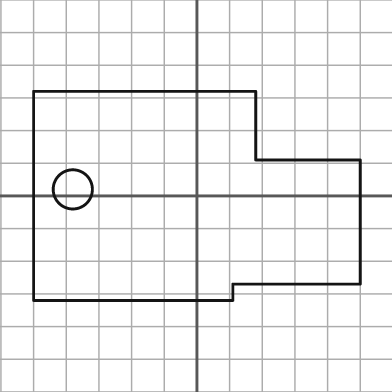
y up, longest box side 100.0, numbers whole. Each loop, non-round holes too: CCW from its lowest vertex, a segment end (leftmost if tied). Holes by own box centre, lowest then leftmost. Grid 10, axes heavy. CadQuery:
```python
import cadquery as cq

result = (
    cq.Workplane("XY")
    .moveTo(-50.0, -32.0)
    .lineTo(11.0, -32.0)
    .lineTo(11.0, -27.0)
    .lineTo(50.0, -27.0)
    .lineTo(50.0, 11.0)
    .lineTo(18.0, 11.0)
    .lineTo(18.0, 32.0)
    .lineTo(-50.0, 32.0)
    .close()
    .moveTo(-38.0, 2.0)
    .circle(6.0)
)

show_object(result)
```